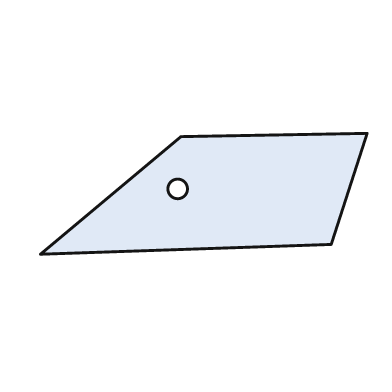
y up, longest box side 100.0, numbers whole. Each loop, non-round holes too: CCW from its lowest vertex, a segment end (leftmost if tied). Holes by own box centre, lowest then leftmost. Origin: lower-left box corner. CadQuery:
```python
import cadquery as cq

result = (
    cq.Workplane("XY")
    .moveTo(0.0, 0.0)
    .lineTo(89.0, 3.0)
    .lineTo(100.0, 37.0)
    .lineTo(43.0, 36.0)
    .close()
    .moveTo(42.0, 20.0)
    .circle(3.0)
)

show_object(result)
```